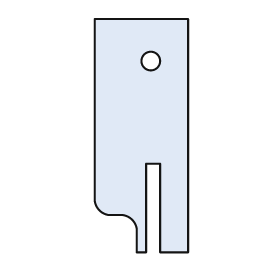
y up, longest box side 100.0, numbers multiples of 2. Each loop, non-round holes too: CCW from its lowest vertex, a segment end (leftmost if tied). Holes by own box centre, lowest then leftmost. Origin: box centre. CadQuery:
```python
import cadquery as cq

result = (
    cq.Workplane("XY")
    .moveTo(-2.0, -50.0)
    .lineTo(2.0, -50.0)
    .lineTo(2.0, -12.0)
    .lineTo(8.0, -12.0)
    .lineTo(8.0, -50.0)
    .lineTo(20.0, -50.0)
    .lineTo(20.0, 50.0)
    .lineTo(-20.0, 50.0)
    .lineTo(-20.0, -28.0)
    .threePointArc((-18.0, -32.0), (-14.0, -34.0))
    .lineTo(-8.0, -34.0)
    .threePointArc((-4.0, -36.0), (-2.0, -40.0))
    .close()
    .moveTo(4.0, 32.0)
    .circle(4.0)
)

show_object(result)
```